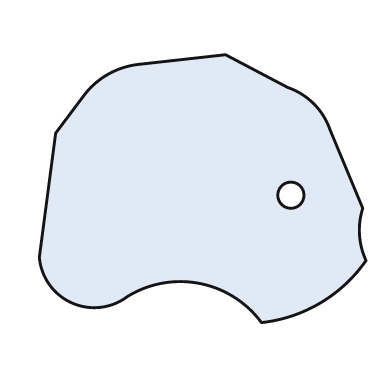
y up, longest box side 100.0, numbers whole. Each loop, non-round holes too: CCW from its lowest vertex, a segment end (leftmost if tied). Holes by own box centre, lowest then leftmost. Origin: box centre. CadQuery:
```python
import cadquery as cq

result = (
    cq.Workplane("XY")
    .moveTo(18.0, -41.0)
    .threePointArc((36.0, -35.0), (50.0, -22.0))
    .threePointArc((48.0, -14.0), (49.0, -6.0))
    .lineTo(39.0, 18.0)
    .threePointArc((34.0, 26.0), (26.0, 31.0))
    .lineTo(7.0, 41.0)
    .lineTo(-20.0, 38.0)
    .threePointArc((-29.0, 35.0), (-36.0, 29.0))
    .lineTo(-45.0, 17.0)
    .lineTo(-50.0, -21.0)
    .threePointArc((-40.0, -35.0), (-23.0, -33.0))
    .threePointArc((-1.0, -29.0), (18.0, -41.0))
    .close()
    .moveTo(27.0, -2.0)
    .circle(4.0)
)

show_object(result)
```